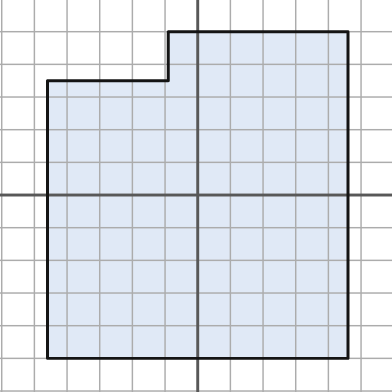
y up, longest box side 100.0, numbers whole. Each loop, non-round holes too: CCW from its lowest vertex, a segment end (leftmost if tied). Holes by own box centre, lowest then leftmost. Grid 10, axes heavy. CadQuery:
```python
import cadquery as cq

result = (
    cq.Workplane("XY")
    .moveTo(-46.0, -50.0)
    .lineTo(46.0, -50.0)
    .lineTo(46.0, 50.0)
    .lineTo(-9.0, 50.0)
    .lineTo(-9.0, 35.0)
    .lineTo(-46.0, 35.0)
    .close()
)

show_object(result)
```